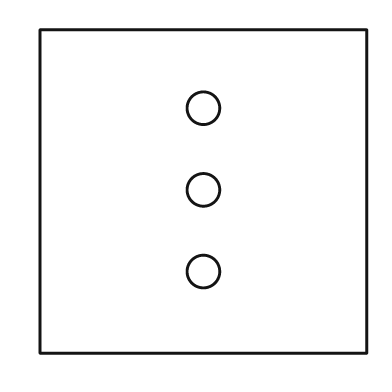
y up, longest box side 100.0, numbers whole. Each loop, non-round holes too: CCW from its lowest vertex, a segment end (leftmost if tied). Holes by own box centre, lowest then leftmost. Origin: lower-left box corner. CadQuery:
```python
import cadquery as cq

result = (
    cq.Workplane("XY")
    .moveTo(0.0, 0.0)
    .lineTo(100.0, 0.0)
    .lineTo(100.0, 99.0)
    .lineTo(0.0, 99.0)
    .close()
    .moveTo(50.0, 25.0)
    .circle(5.0)
    .moveTo(50.0, 50.0)
    .circle(5.0)
    .moveTo(50.0, 75.0)
    .circle(5.0)
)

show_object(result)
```